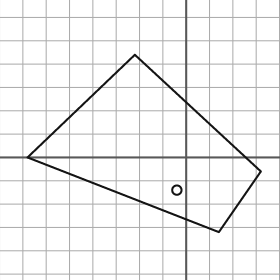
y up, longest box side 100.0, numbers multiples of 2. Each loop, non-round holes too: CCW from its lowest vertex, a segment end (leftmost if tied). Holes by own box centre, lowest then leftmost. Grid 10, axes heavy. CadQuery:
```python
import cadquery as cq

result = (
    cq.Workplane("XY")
    .moveTo(14.0, -32.0)
    .lineTo(32.0, -6.0)
    .lineTo(-22.0, 44.0)
    .lineTo(-68.0, 0.0)
    .close()
    .moveTo(-4.0, -14.0)
    .circle(2.0)
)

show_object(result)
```